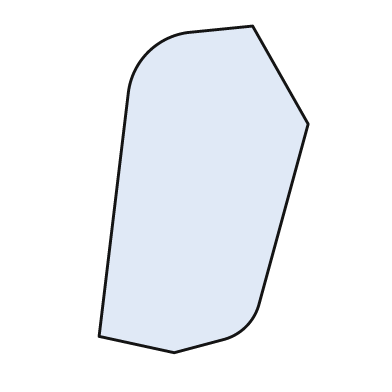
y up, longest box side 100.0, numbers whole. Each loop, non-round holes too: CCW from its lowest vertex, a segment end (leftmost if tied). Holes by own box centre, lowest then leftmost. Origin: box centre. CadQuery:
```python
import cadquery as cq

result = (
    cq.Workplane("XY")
    .moveTo(-9.0, -50.0)
    .lineTo(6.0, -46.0)
    .threePointArc((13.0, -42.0), (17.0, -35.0))
    .lineTo(32.0, 20.0)
    .lineTo(15.0, 50.0)
    .lineTo(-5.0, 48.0)
    .threePointArc((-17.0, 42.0), (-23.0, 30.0))
    .lineTo(-32.0, -45.0)
    .close()
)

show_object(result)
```